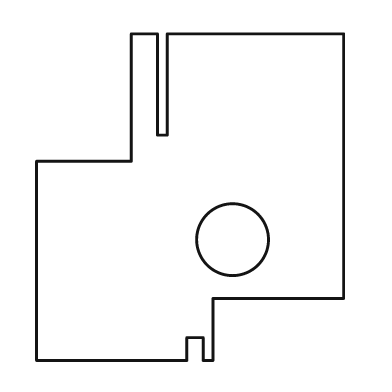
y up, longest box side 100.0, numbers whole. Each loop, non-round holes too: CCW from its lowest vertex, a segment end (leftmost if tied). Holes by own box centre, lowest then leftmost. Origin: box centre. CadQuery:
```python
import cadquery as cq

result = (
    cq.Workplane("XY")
    .moveTo(-47.0, -50.0)
    .lineTo(-1.0, -50.0)
    .lineTo(-1.0, -43.0)
    .lineTo(4.0, -43.0)
    .lineTo(4.0, -50.0)
    .lineTo(7.0, -50.0)
    .lineTo(7.0, -31.0)
    .lineTo(47.0, -31.0)
    .lineTo(47.0, 50.0)
    .lineTo(-7.0, 50.0)
    .lineTo(-7.0, 19.0)
    .lineTo(-10.0, 19.0)
    .lineTo(-10.0, 50.0)
    .lineTo(-18.0, 50.0)
    .lineTo(-18.0, 11.0)
    .lineTo(-47.0, 11.0)
    .close()
    .moveTo(13.0, -13.0)
    .circle(11.0)
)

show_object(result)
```